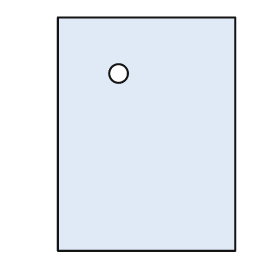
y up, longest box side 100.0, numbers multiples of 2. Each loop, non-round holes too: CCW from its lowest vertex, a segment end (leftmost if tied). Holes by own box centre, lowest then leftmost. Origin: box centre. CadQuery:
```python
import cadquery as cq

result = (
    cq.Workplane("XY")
    .moveTo(-38.0, -50.0)
    .lineTo(38.0, -50.0)
    .lineTo(38.0, 50.0)
    .lineTo(-38.0, 50.0)
    .close()
    .moveTo(-12.0, 26.0)
    .circle(4.0)
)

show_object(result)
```